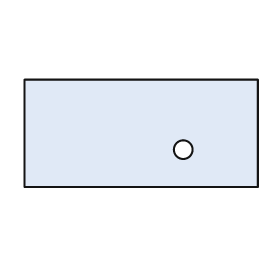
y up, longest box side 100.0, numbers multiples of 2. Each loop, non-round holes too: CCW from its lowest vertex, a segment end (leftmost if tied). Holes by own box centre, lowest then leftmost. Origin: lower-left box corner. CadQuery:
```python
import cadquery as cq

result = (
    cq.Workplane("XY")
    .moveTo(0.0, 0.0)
    .lineTo(100.0, 0.0)
    .lineTo(100.0, 46.0)
    .lineTo(0.0, 46.0)
    .close()
    .moveTo(68.0, 16.0)
    .circle(4.0)
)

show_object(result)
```